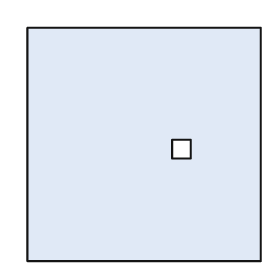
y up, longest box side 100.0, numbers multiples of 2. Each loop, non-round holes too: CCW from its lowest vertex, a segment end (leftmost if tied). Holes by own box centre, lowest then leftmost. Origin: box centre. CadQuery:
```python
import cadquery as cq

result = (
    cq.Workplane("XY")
    .moveTo(-50.0, -50.0)
    .lineTo(50.0, -50.0)
    .lineTo(50.0, 50.0)
    .lineTo(-50.0, 50.0)
    .close()
    .moveTo(12.0, -6.0)
    .lineTo(20.0, -6.0)
    .lineTo(20.0, 2.0)
    .lineTo(12.0, 2.0)
    .close()
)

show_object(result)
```